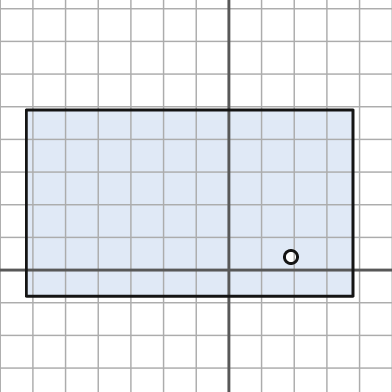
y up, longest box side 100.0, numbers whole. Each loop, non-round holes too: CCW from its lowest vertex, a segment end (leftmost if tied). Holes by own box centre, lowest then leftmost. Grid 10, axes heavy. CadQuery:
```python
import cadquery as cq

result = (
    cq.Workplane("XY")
    .moveTo(-62.0, -8.0)
    .lineTo(38.0, -8.0)
    .lineTo(38.0, 49.0)
    .lineTo(-62.0, 49.0)
    .close()
    .moveTo(19.0, 4.0)
    .circle(2.0)
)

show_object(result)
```